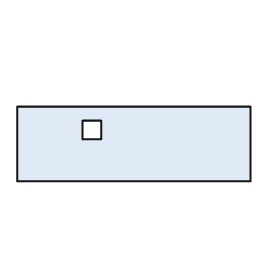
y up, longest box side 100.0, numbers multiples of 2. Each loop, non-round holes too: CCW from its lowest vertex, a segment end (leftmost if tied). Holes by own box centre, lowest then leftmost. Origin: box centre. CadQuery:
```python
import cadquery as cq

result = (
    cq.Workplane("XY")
    .moveTo(-50.0, -16.0)
    .lineTo(50.0, -16.0)
    .lineTo(50.0, 16.0)
    .lineTo(-50.0, 16.0)
    .close()
    .moveTo(-22.0, 2.0)
    .lineTo(-14.0, 2.0)
    .lineTo(-14.0, 10.0)
    .lineTo(-22.0, 10.0)
    .close()
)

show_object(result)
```